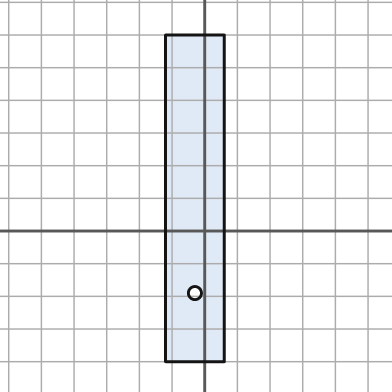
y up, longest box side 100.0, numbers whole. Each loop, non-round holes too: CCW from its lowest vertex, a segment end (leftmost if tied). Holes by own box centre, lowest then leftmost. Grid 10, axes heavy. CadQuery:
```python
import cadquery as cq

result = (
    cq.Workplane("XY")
    .moveTo(-12.0, -40.0)
    .lineTo(6.0, -40.0)
    .lineTo(6.0, 60.0)
    .lineTo(-12.0, 60.0)
    .close()
    .moveTo(-3.0, -19.0)
    .circle(2.0)
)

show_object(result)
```